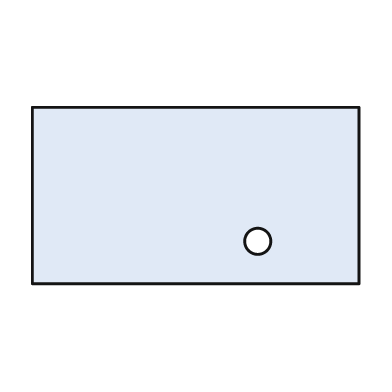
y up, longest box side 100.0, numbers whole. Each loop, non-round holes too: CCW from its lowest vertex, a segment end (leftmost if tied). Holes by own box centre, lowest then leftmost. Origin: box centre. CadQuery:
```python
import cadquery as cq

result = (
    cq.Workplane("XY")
    .moveTo(-50.0, -27.0)
    .lineTo(50.0, -27.0)
    .lineTo(50.0, 27.0)
    .lineTo(-50.0, 27.0)
    .close()
    .moveTo(19.0, -14.0)
    .circle(4.0)
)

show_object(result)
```